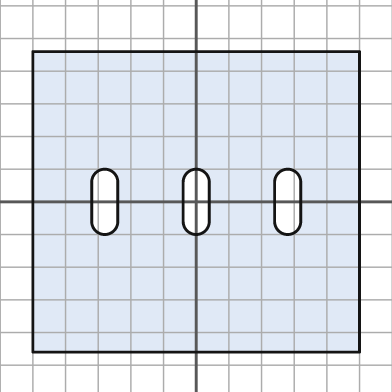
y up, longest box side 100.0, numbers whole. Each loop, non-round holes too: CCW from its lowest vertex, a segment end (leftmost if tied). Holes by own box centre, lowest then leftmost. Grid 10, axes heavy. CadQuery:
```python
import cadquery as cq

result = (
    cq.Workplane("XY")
    .moveTo(-50.0, -46.0)
    .lineTo(50.0, -46.0)
    .lineTo(50.0, 46.0)
    .lineTo(-50.0, 46.0)
    .close()
    .moveTo(-32.0, -6.0)
    .threePointArc((-28.0, -10.0), (-24.0, -6.0))
    .lineTo(-24.0, 6.0)
    .threePointArc((-28.0, 10.0), (-32.0, 6.0))
    .close()
    .moveTo(-4.0, -6.0)
    .threePointArc((0.0, -10.0), (4.0, -6.0))
    .lineTo(4.0, 6.0)
    .threePointArc((0.0, 10.0), (-4.0, 6.0))
    .close()
    .moveTo(24.0, -6.0)
    .threePointArc((28.0, -10.0), (32.0, -6.0))
    .lineTo(32.0, 6.0)
    .threePointArc((28.0, 10.0), (24.0, 6.0))
    .close()
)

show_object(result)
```